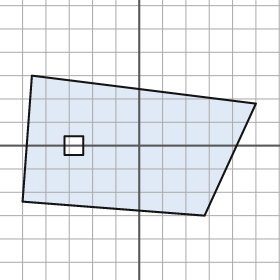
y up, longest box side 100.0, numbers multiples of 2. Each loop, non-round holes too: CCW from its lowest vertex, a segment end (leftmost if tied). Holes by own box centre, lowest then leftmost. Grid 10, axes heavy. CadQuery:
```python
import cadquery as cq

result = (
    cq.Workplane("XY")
    .moveTo(28.0, -30.0)
    .lineTo(50.0, 18.0)
    .lineTo(-46.0, 30.0)
    .lineTo(-50.0, -24.0)
    .close()
    .moveTo(-32.0, -4.0)
    .lineTo(-24.0, -4.0)
    .lineTo(-24.0, 4.0)
    .lineTo(-32.0, 4.0)
    .close()
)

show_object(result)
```